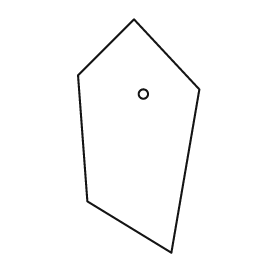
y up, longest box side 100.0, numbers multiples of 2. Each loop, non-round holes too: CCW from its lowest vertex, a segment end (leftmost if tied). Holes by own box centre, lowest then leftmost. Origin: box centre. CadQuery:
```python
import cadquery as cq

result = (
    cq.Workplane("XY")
    .moveTo(14.0, -50.0)
    .lineTo(26.0, 20.0)
    .lineTo(-2.0, 50.0)
    .lineTo(-26.0, 26.0)
    .lineTo(-22.0, -28.0)
    .close()
    .moveTo(2.0, 18.0)
    .circle(2.0)
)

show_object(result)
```